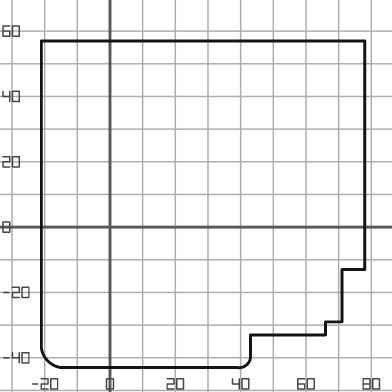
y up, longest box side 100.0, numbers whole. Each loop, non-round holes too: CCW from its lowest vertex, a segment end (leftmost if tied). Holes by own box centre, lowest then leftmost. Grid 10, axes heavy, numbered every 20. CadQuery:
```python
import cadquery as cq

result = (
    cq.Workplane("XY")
    .moveTo(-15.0, -43.0)
    .lineTo(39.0, -43.0)
    .threePointArc((42.0, -42.0), (43.0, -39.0))
    .lineTo(43.0, -33.0)
    .lineTo(66.0, -33.0)
    .lineTo(66.0, -29.0)
    .lineTo(71.0, -29.0)
    .lineTo(71.0, -13.0)
    .lineTo(78.0, -13.0)
    .lineTo(78.0, 57.0)
    .lineTo(-21.0, 57.0)
    .lineTo(-21.0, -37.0)
    .threePointArc((-19.0, -41.0), (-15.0, -43.0))
    .close()
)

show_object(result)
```